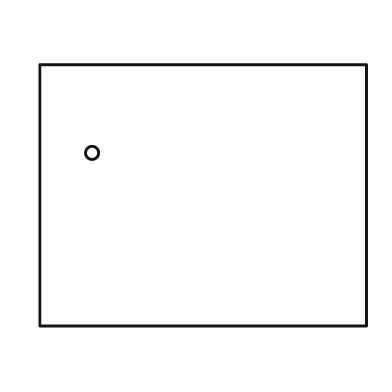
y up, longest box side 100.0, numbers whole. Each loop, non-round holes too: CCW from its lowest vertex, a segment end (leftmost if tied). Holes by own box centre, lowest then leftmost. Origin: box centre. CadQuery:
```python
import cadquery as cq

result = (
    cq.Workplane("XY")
    .moveTo(-50.0, -40.0)
    .lineTo(50.0, -40.0)
    .lineTo(50.0, 40.0)
    .lineTo(-50.0, 40.0)
    .close()
    .moveTo(-34.0, 13.0)
    .circle(2.0)
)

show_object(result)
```